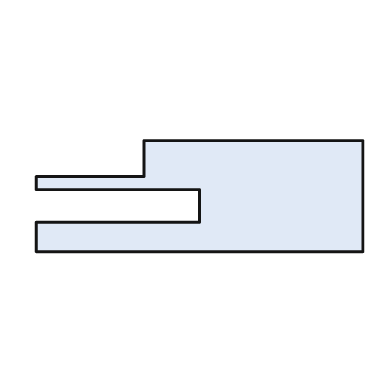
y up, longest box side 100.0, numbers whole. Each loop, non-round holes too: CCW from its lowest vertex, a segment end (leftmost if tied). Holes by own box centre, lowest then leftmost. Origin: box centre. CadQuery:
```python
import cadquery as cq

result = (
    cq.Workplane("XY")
    .moveTo(-50.0, -17.0)
    .lineTo(50.0, -17.0)
    .lineTo(50.0, 17.0)
    .lineTo(-17.0, 17.0)
    .lineTo(-17.0, 6.0)
    .lineTo(-50.0, 6.0)
    .lineTo(-50.0, 2.0)
    .lineTo(0.0, 2.0)
    .lineTo(0.0, -8.0)
    .lineTo(-50.0, -8.0)
    .close()
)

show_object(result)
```